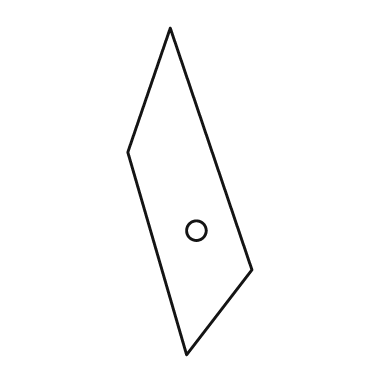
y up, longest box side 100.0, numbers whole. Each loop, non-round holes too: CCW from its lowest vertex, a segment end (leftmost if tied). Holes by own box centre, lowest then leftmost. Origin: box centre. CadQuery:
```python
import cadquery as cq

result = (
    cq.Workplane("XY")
    .moveTo(-1.0, -50.0)
    .lineTo(19.0, -24.0)
    .lineTo(-6.0, 50.0)
    .lineTo(-19.0, 12.0)
    .close()
    .moveTo(2.0, -12.0)
    .circle(3.0)
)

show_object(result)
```